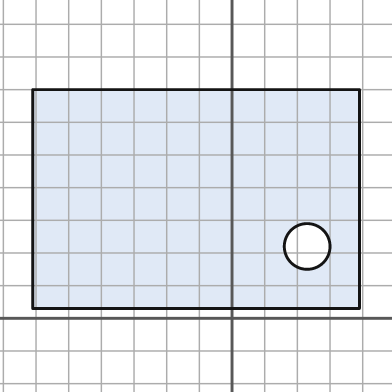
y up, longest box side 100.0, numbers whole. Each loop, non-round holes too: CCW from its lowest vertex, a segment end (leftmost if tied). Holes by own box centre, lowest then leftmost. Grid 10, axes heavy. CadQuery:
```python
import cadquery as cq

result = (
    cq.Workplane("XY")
    .moveTo(-61.0, 3.0)
    .lineTo(39.0, 3.0)
    .lineTo(39.0, 70.0)
    .lineTo(-61.0, 70.0)
    .close()
    .moveTo(23.0, 22.0)
    .circle(7.0)
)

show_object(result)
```